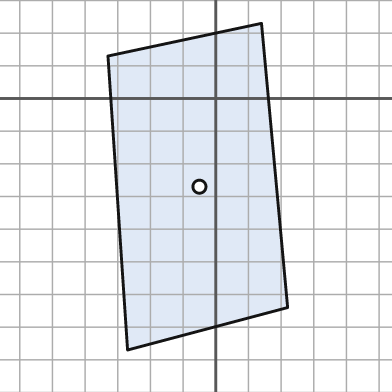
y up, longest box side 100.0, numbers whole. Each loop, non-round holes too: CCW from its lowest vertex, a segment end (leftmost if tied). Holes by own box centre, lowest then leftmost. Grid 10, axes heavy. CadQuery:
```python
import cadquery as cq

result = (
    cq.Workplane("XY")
    .moveTo(-27.0, -77.0)
    .lineTo(22.0, -64.0)
    .lineTo(14.0, 23.0)
    .lineTo(-33.0, 13.0)
    .close()
    .moveTo(-5.0, -27.0)
    .circle(2.0)
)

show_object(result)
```